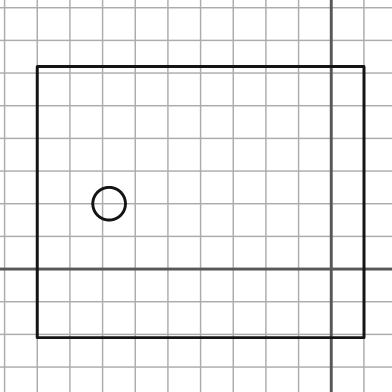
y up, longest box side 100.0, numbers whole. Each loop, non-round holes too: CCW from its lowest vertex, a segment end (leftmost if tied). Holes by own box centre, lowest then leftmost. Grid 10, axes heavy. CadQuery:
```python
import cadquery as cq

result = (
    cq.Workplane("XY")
    .moveTo(-90.0, -21.0)
    .lineTo(10.0, -21.0)
    .lineTo(10.0, 62.0)
    .lineTo(-90.0, 62.0)
    .close()
    .moveTo(-68.0, 20.0)
    .circle(5.0)
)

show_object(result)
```